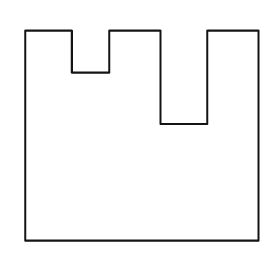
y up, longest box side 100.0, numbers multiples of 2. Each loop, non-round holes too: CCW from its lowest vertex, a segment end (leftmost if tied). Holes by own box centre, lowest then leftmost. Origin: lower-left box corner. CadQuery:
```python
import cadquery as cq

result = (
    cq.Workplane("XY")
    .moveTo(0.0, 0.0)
    .lineTo(100.0, 0.0)
    .lineTo(100.0, 90.0)
    .lineTo(78.0, 90.0)
    .lineTo(78.0, 50.0)
    .lineTo(58.0, 50.0)
    .lineTo(58.0, 90.0)
    .lineTo(36.0, 90.0)
    .lineTo(36.0, 72.0)
    .lineTo(20.0, 72.0)
    .lineTo(20.0, 90.0)
    .lineTo(0.0, 90.0)
    .close()
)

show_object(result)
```